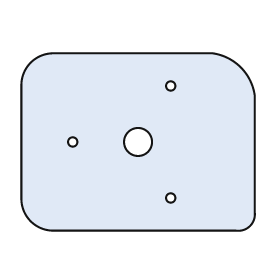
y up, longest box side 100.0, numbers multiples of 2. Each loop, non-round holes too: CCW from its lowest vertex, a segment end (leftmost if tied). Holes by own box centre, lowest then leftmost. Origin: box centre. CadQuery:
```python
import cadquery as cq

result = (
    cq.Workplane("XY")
    .moveTo(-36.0, -38.0)
    .lineTo(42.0, -38.0)
    .threePointArc((48.0, -36.0), (50.0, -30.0))
    .lineTo(50.0, 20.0)
    .threePointArc((44.0, 32.0), (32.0, 38.0))
    .lineTo(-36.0, 38.0)
    .threePointArc((-46.0, 34.0), (-50.0, 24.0))
    .lineTo(-50.0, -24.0)
    .threePointArc((-46.0, -34.0), (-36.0, -38.0))
    .close()
    .moveTo(14.0, -24.0)
    .circle(2.0)
    .moveTo(-28.0, 0.0)
    .circle(2.0)
    .moveTo(0.0, 0.0)
    .circle(6.0)
    .moveTo(14.0, 24.0)
    .circle(2.0)
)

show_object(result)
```